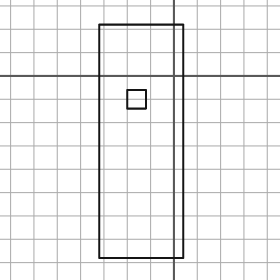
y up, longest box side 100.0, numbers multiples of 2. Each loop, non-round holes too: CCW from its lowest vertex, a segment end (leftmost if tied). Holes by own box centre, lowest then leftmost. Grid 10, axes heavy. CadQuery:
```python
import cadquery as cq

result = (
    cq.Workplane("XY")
    .moveTo(-32.0, -78.0)
    .lineTo(4.0, -78.0)
    .lineTo(4.0, 22.0)
    .lineTo(-32.0, 22.0)
    .close()
    .moveTo(-20.0, -14.0)
    .lineTo(-12.0, -14.0)
    .lineTo(-12.0, -6.0)
    .lineTo(-20.0, -6.0)
    .close()
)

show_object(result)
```